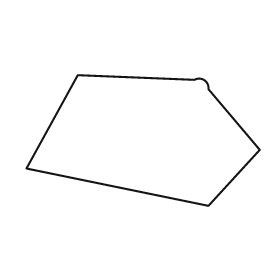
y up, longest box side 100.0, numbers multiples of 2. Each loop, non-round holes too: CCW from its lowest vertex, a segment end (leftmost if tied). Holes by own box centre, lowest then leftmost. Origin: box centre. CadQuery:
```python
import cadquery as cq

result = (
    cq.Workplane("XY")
    .moveTo(28.0, -28.0)
    .lineTo(50.0, -4.0)
    .lineTo(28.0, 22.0)
    .threePointArc((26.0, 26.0), (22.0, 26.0))
    .lineTo(-28.0, 28.0)
    .lineTo(-50.0, -12.0)
    .close()
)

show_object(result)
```